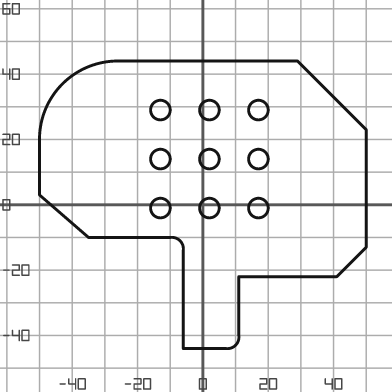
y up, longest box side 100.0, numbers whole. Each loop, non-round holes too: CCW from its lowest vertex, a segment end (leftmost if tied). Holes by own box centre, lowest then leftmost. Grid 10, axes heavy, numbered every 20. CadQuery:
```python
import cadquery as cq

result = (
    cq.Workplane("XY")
    .moveTo(-6.0, -44.0)
    .lineTo(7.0, -44.0)
    .threePointArc((10.0, -43.0), (11.0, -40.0))
    .lineTo(11.0, -22.0)
    .lineTo(41.0, -22.0)
    .lineTo(50.0, -13.0)
    .lineTo(50.0, 23.0)
    .lineTo(29.0, 44.0)
    .lineTo(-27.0, 44.0)
    .threePointArc((-43.0, 37.0), (-50.0, 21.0))
    .lineTo(-50.0, 3.0)
    .lineTo(-35.0, -10.0)
    .lineTo(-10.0, -10.0)
    .threePointArc((-7.0, -11.0), (-6.0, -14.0))
    .close()
    .moveTo(-13.0, -1.0)
    .circle(3.0)
    .moveTo(2.0, -1.0)
    .circle(3.0)
    .moveTo(17.0, -1.0)
    .circle(3.0)
    .moveTo(-13.0, 14.0)
    .circle(3.0)
    .moveTo(2.0, 14.0)
    .circle(3.0)
    .moveTo(17.0, 14.0)
    .circle(3.0)
    .moveTo(-13.0, 29.0)
    .circle(3.0)
    .moveTo(2.0, 29.0)
    .circle(3.0)
    .moveTo(17.0, 29.0)
    .circle(3.0)
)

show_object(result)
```